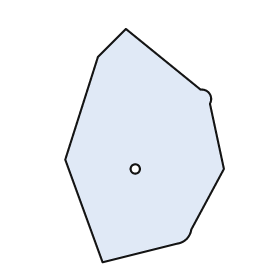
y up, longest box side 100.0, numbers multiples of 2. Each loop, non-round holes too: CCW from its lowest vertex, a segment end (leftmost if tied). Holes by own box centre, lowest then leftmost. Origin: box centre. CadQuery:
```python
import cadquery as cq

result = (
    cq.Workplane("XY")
    .moveTo(-18.0, -50.0)
    .lineTo(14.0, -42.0)
    .threePointArc((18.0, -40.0), (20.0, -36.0))
    .lineTo(34.0, -10.0)
    .lineTo(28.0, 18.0)
    .threePointArc((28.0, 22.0), (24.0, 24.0))
    .lineTo(-8.0, 50.0)
    .lineTo(-20.0, 38.0)
    .lineTo(-34.0, -6.0)
    .close()
    .moveTo(-4.0, -10.0)
    .circle(2.0)
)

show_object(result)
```